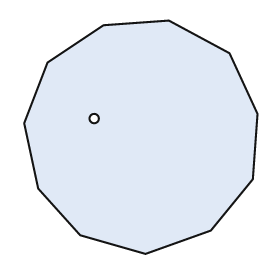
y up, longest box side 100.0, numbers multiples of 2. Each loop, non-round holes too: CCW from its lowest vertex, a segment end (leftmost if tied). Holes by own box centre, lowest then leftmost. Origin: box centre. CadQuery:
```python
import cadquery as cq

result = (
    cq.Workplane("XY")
    .moveTo(2.0, -50.0)
    .lineTo(30.0, -40.0)
    .lineTo(48.0, -18.0)
    .lineTo(50.0, 10.0)
    .lineTo(38.0, 36.0)
    .lineTo(12.0, 50.0)
    .lineTo(-16.0, 48.0)
    .lineTo(-40.0, 32.0)
    .lineTo(-50.0, 6.0)
    .lineTo(-44.0, -22.0)
    .lineTo(-26.0, -42.0)
    .close()
    .moveTo(-20.0, 8.0)
    .circle(2.0)
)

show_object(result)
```